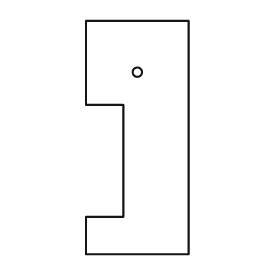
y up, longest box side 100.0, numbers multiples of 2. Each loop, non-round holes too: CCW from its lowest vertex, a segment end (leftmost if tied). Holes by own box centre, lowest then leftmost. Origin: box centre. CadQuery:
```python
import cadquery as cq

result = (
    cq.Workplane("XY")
    .moveTo(-22.0, -50.0)
    .lineTo(22.0, -50.0)
    .lineTo(22.0, 50.0)
    .lineTo(-22.0, 50.0)
    .lineTo(-22.0, 14.0)
    .lineTo(-6.0, 14.0)
    .lineTo(-6.0, -34.0)
    .lineTo(-22.0, -34.0)
    .close()
    .moveTo(0.0, 28.0)
    .circle(2.0)
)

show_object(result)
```